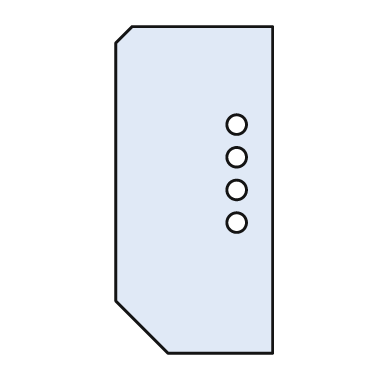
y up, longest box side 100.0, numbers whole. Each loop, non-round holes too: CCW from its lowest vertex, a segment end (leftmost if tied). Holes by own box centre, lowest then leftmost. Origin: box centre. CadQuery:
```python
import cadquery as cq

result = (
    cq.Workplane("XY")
    .moveTo(-8.0, -50.0)
    .lineTo(24.0, -50.0)
    .lineTo(24.0, 50.0)
    .lineTo(-19.0, 50.0)
    .lineTo(-24.0, 45.0)
    .lineTo(-24.0, -34.0)
    .close()
    .moveTo(13.0, -10.0)
    .circle(3.0)
    .moveTo(13.0, 0.0)
    .circle(3.0)
    .moveTo(13.0, 10.0)
    .circle(3.0)
    .moveTo(13.0, 20.0)
    .circle(3.0)
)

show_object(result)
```